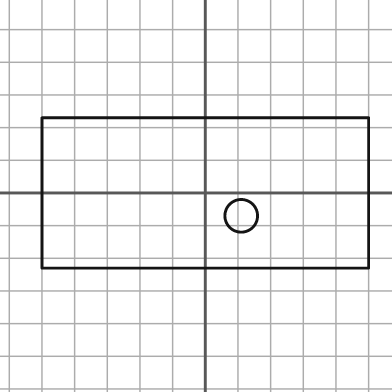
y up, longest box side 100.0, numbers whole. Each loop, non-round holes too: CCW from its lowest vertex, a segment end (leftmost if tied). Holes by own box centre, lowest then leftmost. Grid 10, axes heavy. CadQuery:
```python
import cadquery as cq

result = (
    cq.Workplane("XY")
    .moveTo(-50.0, -23.0)
    .lineTo(50.0, -23.0)
    .lineTo(50.0, 23.0)
    .lineTo(-50.0, 23.0)
    .close()
    .moveTo(11.0, -7.0)
    .circle(5.0)
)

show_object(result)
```